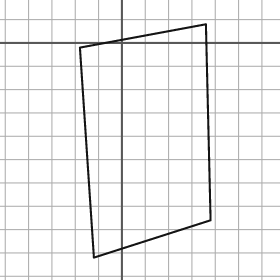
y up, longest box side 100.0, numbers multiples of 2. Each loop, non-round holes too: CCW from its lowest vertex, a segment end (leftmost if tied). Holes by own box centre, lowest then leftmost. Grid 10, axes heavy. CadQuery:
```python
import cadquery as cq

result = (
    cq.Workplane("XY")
    .moveTo(-12.0, -92.0)
    .lineTo(38.0, -76.0)
    .lineTo(36.0, 8.0)
    .lineTo(-18.0, -2.0)
    .close()
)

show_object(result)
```